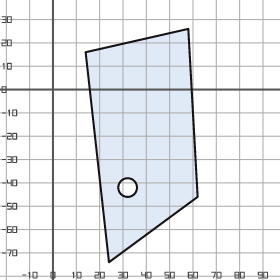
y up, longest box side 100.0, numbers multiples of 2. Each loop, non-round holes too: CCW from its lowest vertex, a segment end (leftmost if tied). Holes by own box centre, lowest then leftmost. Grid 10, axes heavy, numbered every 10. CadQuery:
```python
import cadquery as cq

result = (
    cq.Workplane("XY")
    .moveTo(24.0, -74.0)
    .lineTo(62.0, -46.0)
    .lineTo(58.0, 26.0)
    .lineTo(14.0, 16.0)
    .close()
    .moveTo(32.0, -42.0)
    .circle(4.0)
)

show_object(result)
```